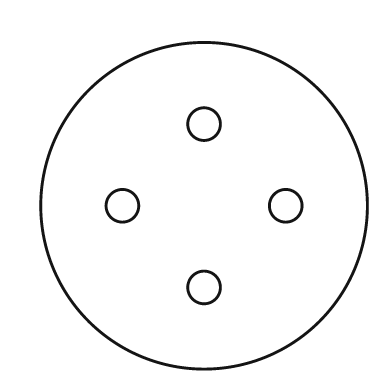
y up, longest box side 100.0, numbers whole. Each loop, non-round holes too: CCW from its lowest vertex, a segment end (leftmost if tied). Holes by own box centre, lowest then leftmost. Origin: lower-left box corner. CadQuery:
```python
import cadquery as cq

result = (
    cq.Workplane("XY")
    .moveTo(50.0, 50.0)
    .circle(50.0)
    .moveTo(50.0, 25.0)
    .circle(5.0)
    .moveTo(25.0, 50.0)
    .circle(5.0)
    .moveTo(75.0, 50.0)
    .circle(5.0)
    .moveTo(50.0, 75.0)
    .circle(5.0)
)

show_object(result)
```